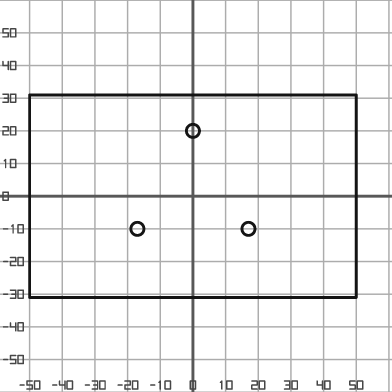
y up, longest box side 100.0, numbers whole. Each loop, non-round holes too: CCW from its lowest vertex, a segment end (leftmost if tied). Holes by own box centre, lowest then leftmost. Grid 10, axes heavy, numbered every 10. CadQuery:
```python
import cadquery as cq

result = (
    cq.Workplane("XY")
    .moveTo(-50.0, -31.0)
    .lineTo(50.0, -31.0)
    .lineTo(50.0, 31.0)
    .lineTo(-50.0, 31.0)
    .close()
    .moveTo(-17.0, -10.0)
    .circle(2.0)
    .moveTo(17.0, -10.0)
    .circle(2.0)
    .moveTo(0.0, 20.0)
    .circle(2.0)
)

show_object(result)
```